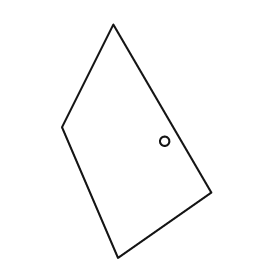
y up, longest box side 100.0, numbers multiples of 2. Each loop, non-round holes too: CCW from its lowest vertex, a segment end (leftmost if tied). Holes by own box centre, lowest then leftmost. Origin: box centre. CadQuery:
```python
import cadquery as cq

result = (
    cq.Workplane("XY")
    .moveTo(-8.0, -50.0)
    .lineTo(32.0, -22.0)
    .lineTo(-10.0, 50.0)
    .lineTo(-32.0, 6.0)
    .close()
    .moveTo(12.0, 0.0)
    .circle(2.0)
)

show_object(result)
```